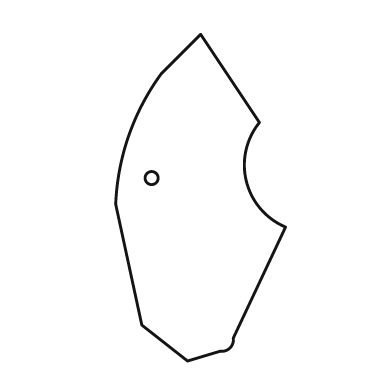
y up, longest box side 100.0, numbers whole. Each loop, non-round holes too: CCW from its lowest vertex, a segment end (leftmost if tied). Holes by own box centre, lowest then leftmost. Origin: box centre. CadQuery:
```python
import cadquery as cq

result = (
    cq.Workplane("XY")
    .moveTo(-4.0, -50.0)
    .lineTo(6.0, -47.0)
    .threePointArc((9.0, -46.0), (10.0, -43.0))
    .lineTo(26.0, -9.0)
    .threePointArc((14.0, 5.0), (18.0, 23.0))
    .lineTo(0.0, 50.0)
    .lineTo(-12.0, 38.0)
    .threePointArc((-22.0, 19.0), (-26.0, -2.0))
    .lineTo(-18.0, -39.0)
    .close()
    .moveTo(-15.0, 6.0)
    .circle(2.0)
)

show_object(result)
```